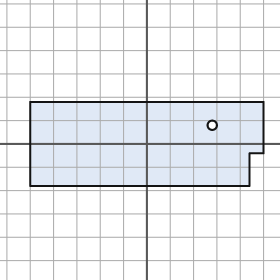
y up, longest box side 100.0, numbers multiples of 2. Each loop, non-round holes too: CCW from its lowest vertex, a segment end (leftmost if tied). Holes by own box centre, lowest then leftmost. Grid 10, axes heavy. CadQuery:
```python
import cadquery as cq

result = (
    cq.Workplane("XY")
    .moveTo(-50.0, -18.0)
    .lineTo(44.0, -18.0)
    .lineTo(44.0, -4.0)
    .lineTo(50.0, -4.0)
    .lineTo(50.0, 18.0)
    .lineTo(-50.0, 18.0)
    .close()
    .moveTo(28.0, 8.0)
    .circle(2.0)
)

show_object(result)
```